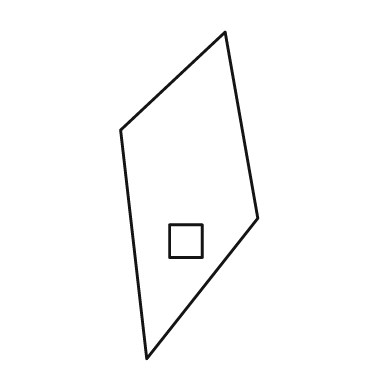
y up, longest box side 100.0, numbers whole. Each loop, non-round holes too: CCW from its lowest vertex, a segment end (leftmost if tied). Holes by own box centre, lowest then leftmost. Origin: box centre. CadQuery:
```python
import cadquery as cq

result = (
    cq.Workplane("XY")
    .moveTo(-13.0, -50.0)
    .lineTo(21.0, -7.0)
    .lineTo(11.0, 50.0)
    .lineTo(-21.0, 20.0)
    .close()
    .moveTo(-6.0, -19.0)
    .lineTo(4.0, -19.0)
    .lineTo(4.0, -9.0)
    .lineTo(-6.0, -9.0)
    .close()
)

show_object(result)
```